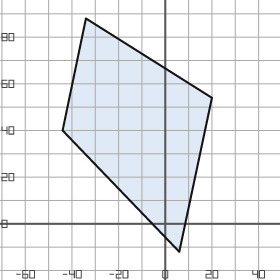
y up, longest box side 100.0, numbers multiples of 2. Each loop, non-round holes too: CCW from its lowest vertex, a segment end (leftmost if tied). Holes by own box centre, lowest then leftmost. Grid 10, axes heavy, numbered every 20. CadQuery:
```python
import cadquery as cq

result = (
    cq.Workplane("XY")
    .moveTo(6.0, -12.0)
    .lineTo(20.0, 54.0)
    .lineTo(-34.0, 88.0)
    .lineTo(-44.0, 40.0)
    .close()
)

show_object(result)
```